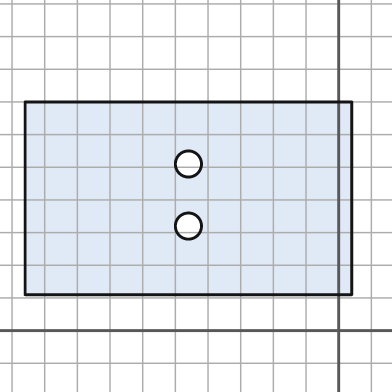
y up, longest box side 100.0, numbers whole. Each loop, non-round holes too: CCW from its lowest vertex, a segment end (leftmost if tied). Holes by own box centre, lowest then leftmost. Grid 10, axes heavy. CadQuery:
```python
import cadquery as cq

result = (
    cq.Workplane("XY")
    .moveTo(-96.0, 11.0)
    .lineTo(4.0, 11.0)
    .lineTo(4.0, 70.0)
    .lineTo(-96.0, 70.0)
    .close()
    .moveTo(-46.0, 32.0)
    .circle(4.0)
    .moveTo(-46.0, 51.0)
    .circle(4.0)
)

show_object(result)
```